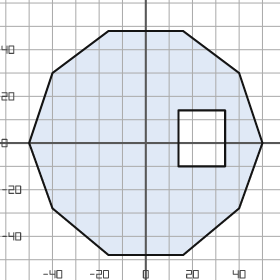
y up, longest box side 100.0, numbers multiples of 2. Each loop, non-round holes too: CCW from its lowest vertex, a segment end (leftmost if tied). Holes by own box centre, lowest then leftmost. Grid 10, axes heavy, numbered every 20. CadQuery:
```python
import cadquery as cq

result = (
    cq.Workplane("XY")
    .moveTo(-16.0, -48.0)
    .lineTo(16.0, -48.0)
    .lineTo(40.0, -28.0)
    .lineTo(50.0, 0.0)
    .lineTo(40.0, 30.0)
    .lineTo(16.0, 48.0)
    .lineTo(-16.0, 48.0)
    .lineTo(-40.0, 30.0)
    .lineTo(-50.0, 0.0)
    .lineTo(-40.0, -28.0)
    .close()
    .moveTo(14.0, -10.0)
    .lineTo(34.0, -10.0)
    .lineTo(34.0, 14.0)
    .lineTo(14.0, 14.0)
    .close()
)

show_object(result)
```